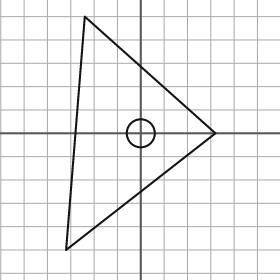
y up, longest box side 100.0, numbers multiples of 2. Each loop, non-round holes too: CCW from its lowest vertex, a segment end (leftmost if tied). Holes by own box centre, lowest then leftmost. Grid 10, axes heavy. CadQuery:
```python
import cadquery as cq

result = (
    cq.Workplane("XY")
    .moveTo(-32.0, -50.0)
    .lineTo(32.0, 0.0)
    .lineTo(-24.0, 50.0)
    .close()
    .moveTo(0.0, 0.0)
    .circle(6.0)
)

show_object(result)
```